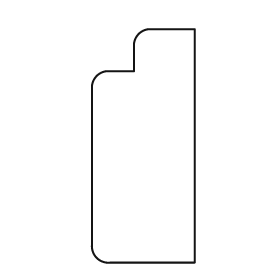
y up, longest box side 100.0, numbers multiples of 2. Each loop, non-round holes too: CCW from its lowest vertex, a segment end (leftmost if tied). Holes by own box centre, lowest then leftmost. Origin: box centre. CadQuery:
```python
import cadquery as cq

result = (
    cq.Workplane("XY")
    .moveTo(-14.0, -50.0)
    .lineTo(22.0, -50.0)
    .lineTo(22.0, 50.0)
    .lineTo(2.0, 50.0)
    .threePointArc((-2.0, 48.0), (-4.0, 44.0))
    .lineTo(-4.0, 32.0)
    .lineTo(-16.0, 32.0)
    .threePointArc((-20.0, 30.0), (-22.0, 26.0))
    .lineTo(-22.0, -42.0)
    .threePointArc((-20.0, -48.0), (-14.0, -50.0))
    .close()
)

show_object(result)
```